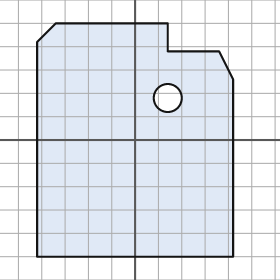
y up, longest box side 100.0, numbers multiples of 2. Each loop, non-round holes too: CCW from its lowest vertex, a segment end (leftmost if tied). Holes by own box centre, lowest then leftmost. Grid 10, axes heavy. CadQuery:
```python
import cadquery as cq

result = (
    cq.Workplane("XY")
    .moveTo(-42.0, -50.0)
    .lineTo(42.0, -50.0)
    .lineTo(42.0, 26.0)
    .lineTo(36.0, 38.0)
    .lineTo(14.0, 38.0)
    .lineTo(14.0, 50.0)
    .lineTo(-34.0, 50.0)
    .lineTo(-42.0, 42.0)
    .close()
    .moveTo(14.0, 18.0)
    .circle(6.0)
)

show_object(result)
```